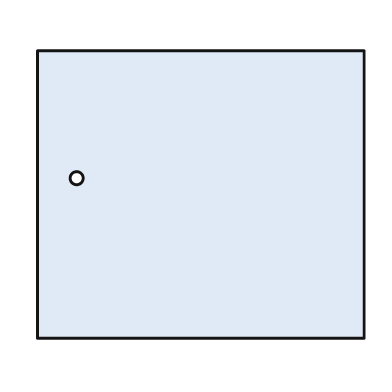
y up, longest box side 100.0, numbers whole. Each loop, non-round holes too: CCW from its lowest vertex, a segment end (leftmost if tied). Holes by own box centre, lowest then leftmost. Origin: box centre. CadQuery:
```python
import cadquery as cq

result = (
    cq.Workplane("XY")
    .moveTo(-50.0, -44.0)
    .lineTo(50.0, -44.0)
    .lineTo(50.0, 44.0)
    .lineTo(-50.0, 44.0)
    .close()
    .moveTo(-38.0, 5.0)
    .circle(2.0)
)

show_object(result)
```